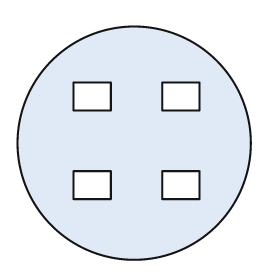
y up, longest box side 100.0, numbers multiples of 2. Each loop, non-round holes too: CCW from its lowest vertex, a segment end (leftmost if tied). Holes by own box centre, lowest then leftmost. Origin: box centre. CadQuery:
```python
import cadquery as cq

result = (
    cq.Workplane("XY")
    .moveTo(0.0, 0.0)
    .circle(50.0)
    .moveTo(-26.0, -24.0)
    .lineTo(-10.0, -24.0)
    .lineTo(-10.0, -12.0)
    .lineTo(-26.0, -12.0)
    .close()
    .moveTo(12.0, -24.0)
    .lineTo(28.0, -24.0)
    .lineTo(28.0, -12.0)
    .lineTo(12.0, -12.0)
    .close()
    .moveTo(-26.0, 14.0)
    .lineTo(-10.0, 14.0)
    .lineTo(-10.0, 26.0)
    .lineTo(-26.0, 26.0)
    .close()
    .moveTo(12.0, 14.0)
    .lineTo(28.0, 14.0)
    .lineTo(28.0, 26.0)
    .lineTo(12.0, 26.0)
    .close()
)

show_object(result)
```